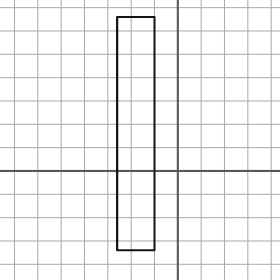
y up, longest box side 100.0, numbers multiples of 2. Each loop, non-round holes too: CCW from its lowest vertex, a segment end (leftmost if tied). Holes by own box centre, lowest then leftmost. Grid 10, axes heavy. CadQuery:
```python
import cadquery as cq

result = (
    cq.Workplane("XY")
    .moveTo(-26.0, -34.0)
    .lineTo(-10.0, -34.0)
    .lineTo(-10.0, 66.0)
    .lineTo(-26.0, 66.0)
    .close()
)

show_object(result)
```